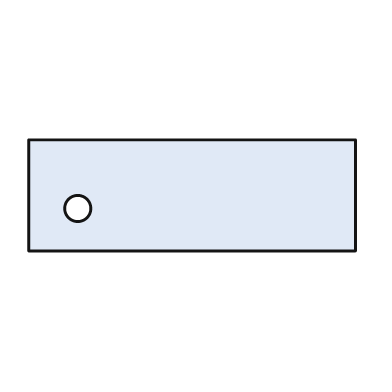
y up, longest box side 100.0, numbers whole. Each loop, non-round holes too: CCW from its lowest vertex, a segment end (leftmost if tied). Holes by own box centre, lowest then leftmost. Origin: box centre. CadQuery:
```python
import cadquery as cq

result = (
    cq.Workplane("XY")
    .moveTo(-50.0, -17.0)
    .lineTo(50.0, -17.0)
    .lineTo(50.0, 17.0)
    .lineTo(-50.0, 17.0)
    .close()
    .moveTo(-35.0, -4.0)
    .circle(4.0)
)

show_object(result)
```